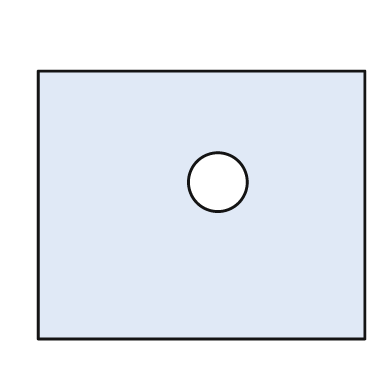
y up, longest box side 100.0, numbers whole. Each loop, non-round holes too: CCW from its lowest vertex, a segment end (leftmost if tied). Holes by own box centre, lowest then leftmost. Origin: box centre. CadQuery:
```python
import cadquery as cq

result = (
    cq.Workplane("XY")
    .moveTo(-50.0, -41.0)
    .lineTo(50.0, -41.0)
    .lineTo(50.0, 41.0)
    .lineTo(-50.0, 41.0)
    .close()
    .moveTo(5.0, 7.0)
    .circle(9.0)
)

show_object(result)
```